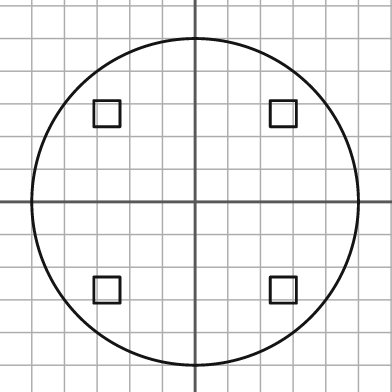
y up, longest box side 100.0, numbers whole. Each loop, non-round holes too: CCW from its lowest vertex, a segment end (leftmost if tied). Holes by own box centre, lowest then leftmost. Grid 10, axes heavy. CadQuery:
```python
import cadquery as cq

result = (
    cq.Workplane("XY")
    .moveTo(0.0, 0.0)
    .circle(50.0)
    .moveTo(-31.0, -31.0)
    .lineTo(-23.0, -31.0)
    .lineTo(-23.0, -23.0)
    .lineTo(-31.0, -23.0)
    .close()
    .moveTo(23.0, -31.0)
    .lineTo(31.0, -31.0)
    .lineTo(31.0, -23.0)
    .lineTo(23.0, -23.0)
    .close()
    .moveTo(-31.0, 23.0)
    .lineTo(-23.0, 23.0)
    .lineTo(-23.0, 31.0)
    .lineTo(-31.0, 31.0)
    .close()
    .moveTo(23.0, 23.0)
    .lineTo(31.0, 23.0)
    .lineTo(31.0, 31.0)
    .lineTo(23.0, 31.0)
    .close()
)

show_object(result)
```